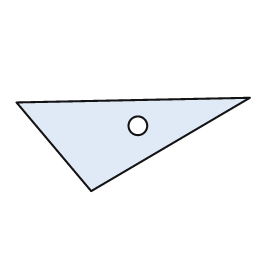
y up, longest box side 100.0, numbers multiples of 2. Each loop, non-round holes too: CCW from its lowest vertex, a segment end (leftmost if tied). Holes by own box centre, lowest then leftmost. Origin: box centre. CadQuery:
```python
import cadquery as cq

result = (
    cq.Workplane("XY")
    .moveTo(-18.0, -20.0)
    .lineTo(50.0, 20.0)
    .lineTo(-50.0, 18.0)
    .close()
    .moveTo(2.0, 8.0)
    .circle(4.0)
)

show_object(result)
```